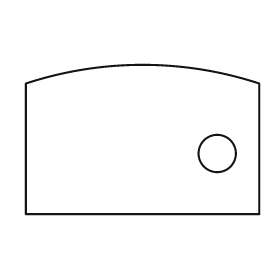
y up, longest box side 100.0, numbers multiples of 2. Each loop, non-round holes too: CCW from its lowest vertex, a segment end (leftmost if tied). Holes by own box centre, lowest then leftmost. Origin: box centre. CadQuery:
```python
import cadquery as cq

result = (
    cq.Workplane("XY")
    .moveTo(-50.0, -32.0)
    .lineTo(50.0, -32.0)
    .lineTo(50.0, 24.0)
    .threePointArc((0.0, 32.0), (-50.0, 24.0))
    .close()
    .moveTo(32.0, -6.0)
    .circle(8.0)
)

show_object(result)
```